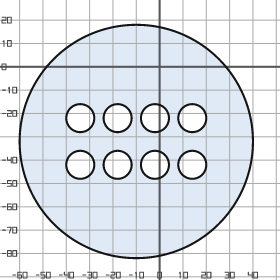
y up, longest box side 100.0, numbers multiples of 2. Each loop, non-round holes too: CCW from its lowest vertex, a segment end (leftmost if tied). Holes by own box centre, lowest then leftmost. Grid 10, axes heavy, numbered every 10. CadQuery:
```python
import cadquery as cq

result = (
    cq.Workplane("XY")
    .moveTo(-10.0, -32.0)
    .circle(50.0)
    .moveTo(-34.0, -42.0)
    .circle(6.0)
    .moveTo(-18.0, -42.0)
    .circle(6.0)
    .moveTo(-2.0, -42.0)
    .circle(6.0)
    .moveTo(14.0, -42.0)
    .circle(6.0)
    .moveTo(-34.0, -22.0)
    .circle(6.0)
    .moveTo(-18.0, -22.0)
    .circle(6.0)
    .moveTo(-2.0, -22.0)
    .circle(6.0)
    .moveTo(14.0, -22.0)
    .circle(6.0)
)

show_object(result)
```